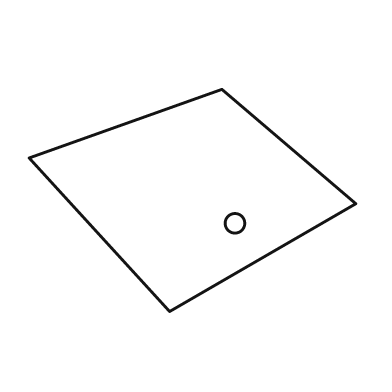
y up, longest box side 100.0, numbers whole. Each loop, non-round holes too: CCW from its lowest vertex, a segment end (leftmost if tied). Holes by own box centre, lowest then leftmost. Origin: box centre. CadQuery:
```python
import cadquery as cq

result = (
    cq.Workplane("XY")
    .moveTo(-7.0, -34.0)
    .lineTo(50.0, -1.0)
    .lineTo(9.0, 34.0)
    .lineTo(-50.0, 13.0)
    .close()
    .moveTo(13.0, -7.0)
    .circle(3.0)
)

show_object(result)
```